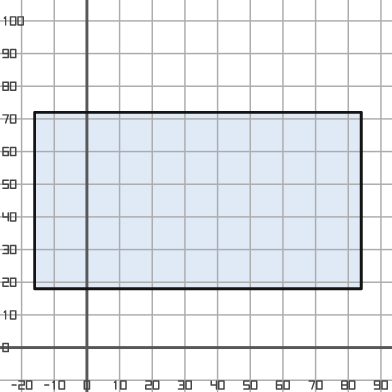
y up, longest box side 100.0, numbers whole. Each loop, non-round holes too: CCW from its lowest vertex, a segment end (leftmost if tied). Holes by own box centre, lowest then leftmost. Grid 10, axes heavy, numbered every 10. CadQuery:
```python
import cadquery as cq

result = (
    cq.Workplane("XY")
    .moveTo(-16.0, 18.0)
    .lineTo(84.0, 18.0)
    .lineTo(84.0, 72.0)
    .lineTo(-16.0, 72.0)
    .close()
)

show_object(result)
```